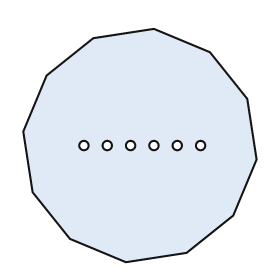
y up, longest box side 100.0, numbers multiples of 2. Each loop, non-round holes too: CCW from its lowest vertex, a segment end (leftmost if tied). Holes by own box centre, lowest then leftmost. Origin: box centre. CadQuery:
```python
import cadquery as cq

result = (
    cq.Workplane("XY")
    .moveTo(-6.0, -50.0)
    .lineTo(20.0, -46.0)
    .lineTo(40.0, -30.0)
    .lineTo(50.0, -6.0)
    .lineTo(46.0, 20.0)
    .lineTo(30.0, 40.0)
    .lineTo(6.0, 50.0)
    .lineTo(-20.0, 46.0)
    .lineTo(-40.0, 30.0)
    .lineTo(-50.0, 6.0)
    .lineTo(-46.0, -20.0)
    .lineTo(-30.0, -40.0)
    .close()
    .moveTo(-24.0, 0.0)
    .circle(2.0)
    .moveTo(-14.0, 0.0)
    .circle(2.0)
    .moveTo(-4.0, 0.0)
    .circle(2.0)
    .moveTo(6.0, 0.0)
    .circle(2.0)
    .moveTo(16.0, 0.0)
    .circle(2.0)
    .moveTo(26.0, 0.0)
    .circle(2.0)
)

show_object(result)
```